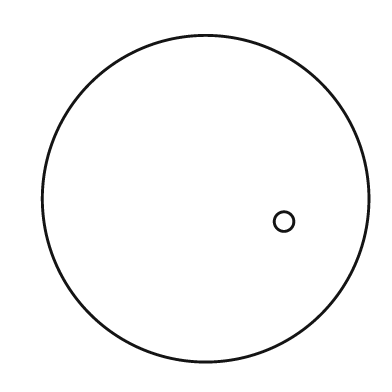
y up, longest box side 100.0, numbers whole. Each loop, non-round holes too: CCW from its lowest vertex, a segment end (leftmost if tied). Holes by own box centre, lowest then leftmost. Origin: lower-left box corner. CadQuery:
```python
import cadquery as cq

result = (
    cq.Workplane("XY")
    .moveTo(50.0, 50.0)
    .circle(50.0)
    .moveTo(74.0, 43.0)
    .circle(3.0)
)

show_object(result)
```